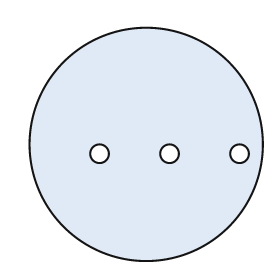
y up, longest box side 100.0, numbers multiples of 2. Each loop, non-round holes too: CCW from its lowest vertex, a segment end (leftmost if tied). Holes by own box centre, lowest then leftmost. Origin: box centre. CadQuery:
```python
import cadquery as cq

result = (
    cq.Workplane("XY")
    .moveTo(0.0, 0.0)
    .circle(50.0)
    .moveTo(-20.0, -4.0)
    .circle(4.0)
    .moveTo(10.0, -4.0)
    .circle(4.0)
    .moveTo(40.0, -4.0)
    .circle(4.0)
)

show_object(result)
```